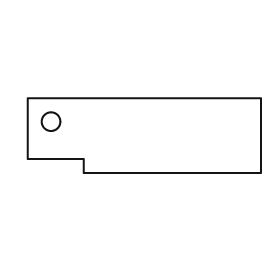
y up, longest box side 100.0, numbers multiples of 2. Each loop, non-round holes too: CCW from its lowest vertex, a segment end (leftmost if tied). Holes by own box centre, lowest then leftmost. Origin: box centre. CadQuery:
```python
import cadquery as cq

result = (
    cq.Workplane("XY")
    .moveTo(-26.0, -16.0)
    .lineTo(50.0, -16.0)
    .lineTo(50.0, 16.0)
    .lineTo(-50.0, 16.0)
    .lineTo(-50.0, -10.0)
    .lineTo(-26.0, -10.0)
    .close()
    .moveTo(-40.0, 6.0)
    .circle(4.0)
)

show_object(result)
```